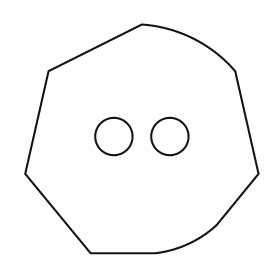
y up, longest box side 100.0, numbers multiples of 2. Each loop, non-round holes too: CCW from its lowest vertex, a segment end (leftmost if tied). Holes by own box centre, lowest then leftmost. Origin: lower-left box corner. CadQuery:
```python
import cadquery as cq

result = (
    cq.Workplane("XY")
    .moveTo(28.0, 0.0)
    .lineTo(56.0, 0.0)
    .threePointArc((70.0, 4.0), (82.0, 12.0))
    .lineTo(100.0, 34.0)
    .lineTo(90.0, 78.0)
    .threePointArc((72.0, 92.0), (50.0, 98.0))
    .lineTo(10.0, 78.0)
    .lineTo(0.0, 34.0)
    .close()
    .moveTo(38.0, 50.0)
    .circle(8.0)
    .moveTo(62.0, 50.0)
    .circle(8.0)
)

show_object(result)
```